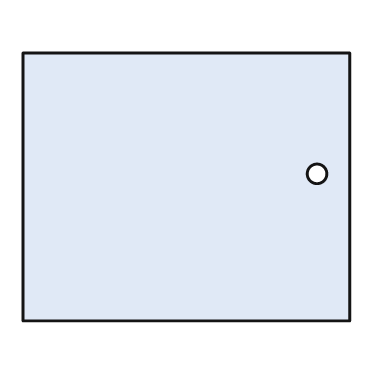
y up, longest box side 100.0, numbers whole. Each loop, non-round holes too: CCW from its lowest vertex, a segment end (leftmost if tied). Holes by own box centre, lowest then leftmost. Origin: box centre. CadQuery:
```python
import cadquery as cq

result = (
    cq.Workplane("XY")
    .moveTo(-50.0, -41.0)
    .lineTo(50.0, -41.0)
    .lineTo(50.0, 41.0)
    .lineTo(-50.0, 41.0)
    .close()
    .moveTo(40.0, 4.0)
    .circle(3.0)
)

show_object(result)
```